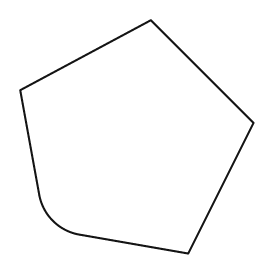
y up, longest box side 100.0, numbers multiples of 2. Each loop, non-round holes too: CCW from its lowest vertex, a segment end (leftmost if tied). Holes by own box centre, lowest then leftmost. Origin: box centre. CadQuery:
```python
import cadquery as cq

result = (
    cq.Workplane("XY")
    .moveTo(22.0, -50.0)
    .lineTo(50.0, 6.0)
    .lineTo(6.0, 50.0)
    .lineTo(-50.0, 20.0)
    .lineTo(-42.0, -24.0)
    .threePointArc((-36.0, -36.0), (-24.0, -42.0))
    .close()
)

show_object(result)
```